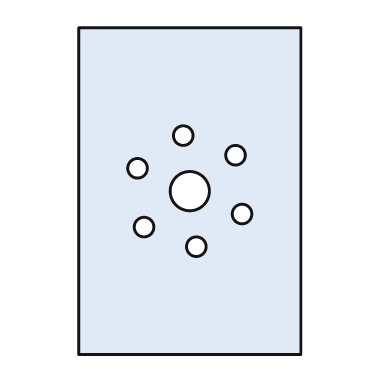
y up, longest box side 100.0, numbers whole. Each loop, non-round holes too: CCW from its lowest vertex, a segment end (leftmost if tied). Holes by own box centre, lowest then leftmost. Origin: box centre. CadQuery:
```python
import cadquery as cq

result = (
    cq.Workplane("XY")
    .moveTo(-34.0, -50.0)
    .lineTo(34.0, -50.0)
    .lineTo(34.0, 50.0)
    .lineTo(-34.0, 50.0)
    .close()
    .moveTo(2.0, -17.0)
    .circle(3.0)
    .moveTo(-14.0, -11.0)
    .circle(3.0)
    .moveTo(16.0, -7.0)
    .circle(3.0)
    .moveTo(0.0, 0.0)
    .circle(6.0)
    .moveTo(-16.0, 7.0)
    .circle(3.0)
    .moveTo(14.0, 11.0)
    .circle(3.0)
    .moveTo(-2.0, 17.0)
    .circle(3.0)
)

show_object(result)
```